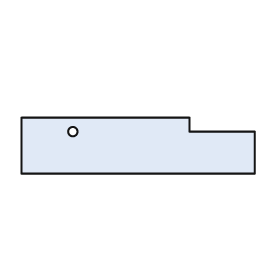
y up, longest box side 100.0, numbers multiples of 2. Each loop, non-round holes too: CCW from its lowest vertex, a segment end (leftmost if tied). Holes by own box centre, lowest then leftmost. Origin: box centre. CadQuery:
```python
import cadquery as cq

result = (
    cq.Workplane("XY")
    .moveTo(-50.0, -12.0)
    .lineTo(50.0, -12.0)
    .lineTo(50.0, 6.0)
    .lineTo(22.0, 6.0)
    .lineTo(22.0, 12.0)
    .lineTo(-50.0, 12.0)
    .close()
    .moveTo(-28.0, 6.0)
    .circle(2.0)
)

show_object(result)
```